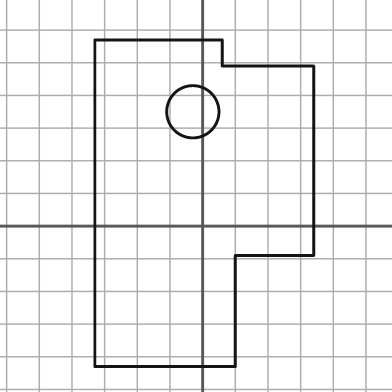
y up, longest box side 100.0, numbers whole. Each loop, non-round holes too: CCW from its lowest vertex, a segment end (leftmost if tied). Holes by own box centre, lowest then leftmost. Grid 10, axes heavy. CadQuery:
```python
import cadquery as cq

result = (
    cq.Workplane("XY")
    .moveTo(-33.0, -43.0)
    .lineTo(10.0, -43.0)
    .lineTo(10.0, -9.0)
    .lineTo(34.0, -9.0)
    .lineTo(34.0, 49.0)
    .lineTo(6.0, 49.0)
    .lineTo(6.0, 57.0)
    .lineTo(-33.0, 57.0)
    .close()
    .moveTo(-3.0, 35.0)
    .circle(8.0)
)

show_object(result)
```